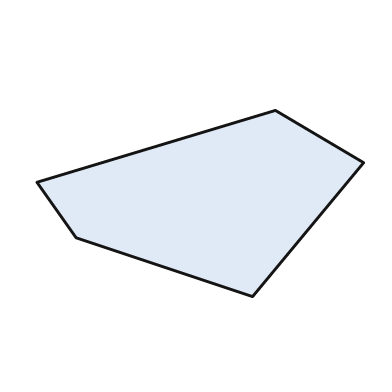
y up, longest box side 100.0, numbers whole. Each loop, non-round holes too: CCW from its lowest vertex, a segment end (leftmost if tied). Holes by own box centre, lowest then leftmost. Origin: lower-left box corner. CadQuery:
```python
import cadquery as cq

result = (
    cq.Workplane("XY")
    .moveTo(66.0, 0.0)
    .lineTo(100.0, 41.0)
    .lineTo(73.0, 57.0)
    .lineTo(0.0, 35.0)
    .lineTo(12.0, 18.0)
    .close()
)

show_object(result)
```